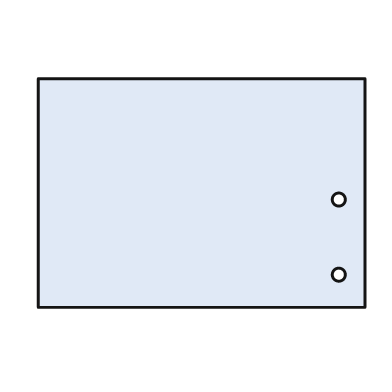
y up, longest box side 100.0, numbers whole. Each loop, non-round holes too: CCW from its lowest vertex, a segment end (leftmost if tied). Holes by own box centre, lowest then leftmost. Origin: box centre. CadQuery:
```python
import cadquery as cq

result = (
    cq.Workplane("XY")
    .moveTo(-50.0, -35.0)
    .lineTo(50.0, -35.0)
    .lineTo(50.0, 35.0)
    .lineTo(-50.0, 35.0)
    .close()
    .moveTo(42.0, -25.0)
    .circle(2.0)
    .moveTo(42.0, -2.0)
    .circle(2.0)
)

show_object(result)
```